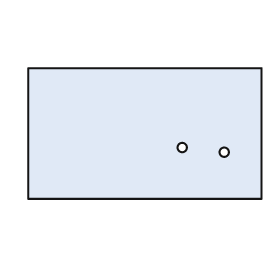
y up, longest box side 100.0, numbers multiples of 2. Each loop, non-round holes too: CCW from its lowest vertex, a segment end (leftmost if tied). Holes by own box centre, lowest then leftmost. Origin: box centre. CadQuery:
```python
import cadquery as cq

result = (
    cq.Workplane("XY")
    .moveTo(-50.0, -28.0)
    .lineTo(50.0, -28.0)
    .lineTo(50.0, 28.0)
    .lineTo(-50.0, 28.0)
    .close()
    .moveTo(34.0, -8.0)
    .circle(2.0)
    .moveTo(16.0, -6.0)
    .circle(2.0)
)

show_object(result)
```